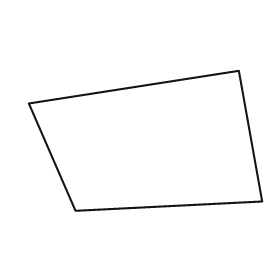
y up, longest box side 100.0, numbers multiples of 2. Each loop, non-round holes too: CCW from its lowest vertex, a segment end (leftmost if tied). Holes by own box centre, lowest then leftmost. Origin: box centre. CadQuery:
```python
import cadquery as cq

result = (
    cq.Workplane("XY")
    .moveTo(-30.0, -30.0)
    .lineTo(50.0, -26.0)
    .lineTo(40.0, 30.0)
    .lineTo(-50.0, 16.0)
    .close()
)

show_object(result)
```